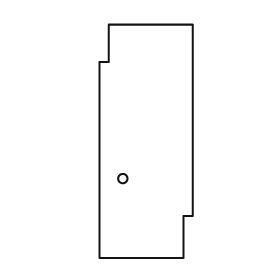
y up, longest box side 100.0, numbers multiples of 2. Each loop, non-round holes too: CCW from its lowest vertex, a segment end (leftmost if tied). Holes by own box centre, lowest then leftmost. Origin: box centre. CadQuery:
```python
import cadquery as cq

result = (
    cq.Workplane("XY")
    .moveTo(-20.0, -50.0)
    .lineTo(16.0, -50.0)
    .lineTo(16.0, -32.0)
    .lineTo(20.0, -32.0)
    .lineTo(20.0, 50.0)
    .lineTo(-16.0, 50.0)
    .lineTo(-16.0, 34.0)
    .lineTo(-20.0, 34.0)
    .close()
    .moveTo(-10.0, -16.0)
    .circle(2.0)
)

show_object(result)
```